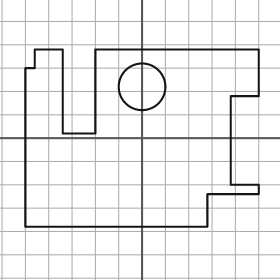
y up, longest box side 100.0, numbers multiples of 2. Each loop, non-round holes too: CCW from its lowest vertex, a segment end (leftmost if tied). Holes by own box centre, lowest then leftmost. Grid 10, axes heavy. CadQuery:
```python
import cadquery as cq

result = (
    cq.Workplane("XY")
    .moveTo(-50.0, -38.0)
    .lineTo(28.0, -38.0)
    .lineTo(28.0, -24.0)
    .lineTo(50.0, -24.0)
    .lineTo(50.0, -20.0)
    .lineTo(38.0, -20.0)
    .lineTo(38.0, 18.0)
    .lineTo(50.0, 18.0)
    .lineTo(50.0, 38.0)
    .lineTo(-20.0, 38.0)
    .lineTo(-20.0, 2.0)
    .lineTo(-34.0, 2.0)
    .lineTo(-34.0, 38.0)
    .lineTo(-46.0, 38.0)
    .lineTo(-46.0, 30.0)
    .lineTo(-50.0, 30.0)
    .close()
    .moveTo(0.0, 22.0)
    .circle(10.0)
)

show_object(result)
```